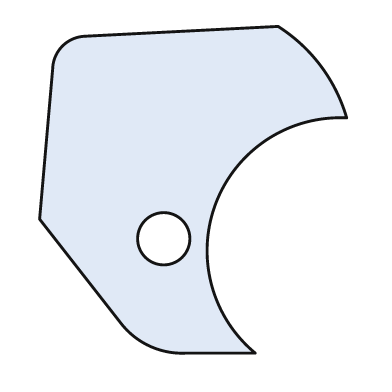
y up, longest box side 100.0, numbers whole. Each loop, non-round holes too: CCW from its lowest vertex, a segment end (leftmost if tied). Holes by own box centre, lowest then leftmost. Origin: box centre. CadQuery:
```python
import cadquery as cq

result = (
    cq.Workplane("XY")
    .moveTo(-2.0, -50.0)
    .lineTo(19.0, -50.0)
    .threePointArc((7.0, -4.0), (47.0, 22.0))
    .threePointArc((39.0, 38.0), (26.0, 50.0))
    .lineTo(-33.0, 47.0)
    .threePointArc((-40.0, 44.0), (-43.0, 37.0))
    .lineTo(-47.0, -9.0)
    .lineTo(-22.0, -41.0)
    .threePointArc((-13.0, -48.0), (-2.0, -50.0))
    .close()
    .moveTo(-9.0, -15.0)
    .circle(8.0)
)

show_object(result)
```